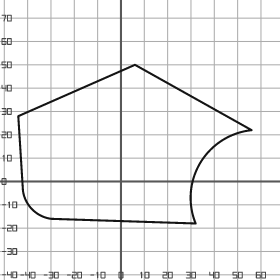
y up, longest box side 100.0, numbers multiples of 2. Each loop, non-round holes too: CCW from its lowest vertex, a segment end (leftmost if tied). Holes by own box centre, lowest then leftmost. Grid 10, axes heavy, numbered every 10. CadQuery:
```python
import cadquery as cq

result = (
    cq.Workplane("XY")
    .moveTo(32.0, -18.0)
    .threePointArc((34.0, 8.0), (56.0, 22.0))
    .lineTo(6.0, 50.0)
    .lineTo(-44.0, 28.0)
    .lineTo(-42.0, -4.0)
    .threePointArc((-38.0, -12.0), (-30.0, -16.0))
    .close()
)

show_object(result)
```